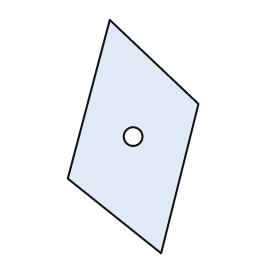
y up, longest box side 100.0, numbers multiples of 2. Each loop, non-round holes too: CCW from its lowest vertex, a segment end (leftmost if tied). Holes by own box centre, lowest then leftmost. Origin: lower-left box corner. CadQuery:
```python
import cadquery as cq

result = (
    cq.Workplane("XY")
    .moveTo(40.0, 0.0)
    .lineTo(56.0, 64.0)
    .lineTo(18.0, 100.0)
    .lineTo(0.0, 32.0)
    .close()
    .moveTo(28.0, 50.0)
    .circle(4.0)
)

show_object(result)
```